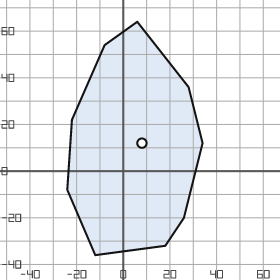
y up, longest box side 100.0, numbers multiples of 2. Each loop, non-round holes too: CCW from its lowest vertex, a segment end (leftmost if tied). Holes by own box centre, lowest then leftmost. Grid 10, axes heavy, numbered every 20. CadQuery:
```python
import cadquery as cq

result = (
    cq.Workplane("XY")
    .moveTo(-12.0, -36.0)
    .lineTo(18.0, -32.0)
    .lineTo(26.0, -20.0)
    .lineTo(34.0, 12.0)
    .lineTo(28.0, 36.0)
    .lineTo(6.0, 64.0)
    .lineTo(-8.0, 54.0)
    .lineTo(-22.0, 22.0)
    .lineTo(-24.0, -8.0)
    .close()
    .moveTo(8.0, 12.0)
    .circle(2.0)
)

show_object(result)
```